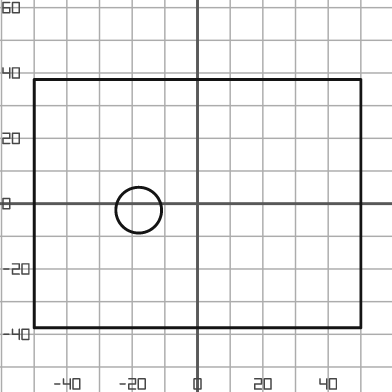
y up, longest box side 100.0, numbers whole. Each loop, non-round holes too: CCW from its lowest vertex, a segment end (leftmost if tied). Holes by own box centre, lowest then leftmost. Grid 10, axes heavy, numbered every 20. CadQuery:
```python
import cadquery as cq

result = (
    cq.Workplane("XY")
    .moveTo(-50.0, -38.0)
    .lineTo(50.0, -38.0)
    .lineTo(50.0, 38.0)
    .lineTo(-50.0, 38.0)
    .close()
    .moveTo(-18.0, -2.0)
    .circle(7.0)
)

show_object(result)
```